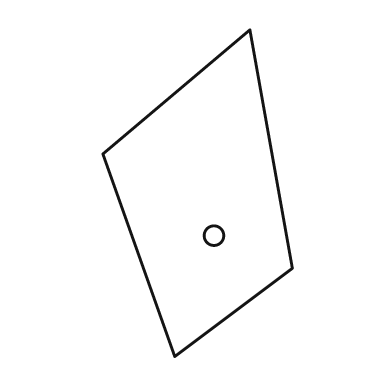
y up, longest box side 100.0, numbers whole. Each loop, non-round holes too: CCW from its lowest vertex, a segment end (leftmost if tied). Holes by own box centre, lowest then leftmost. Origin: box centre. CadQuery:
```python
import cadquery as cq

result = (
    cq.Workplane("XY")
    .moveTo(-7.0, -50.0)
    .lineTo(29.0, -23.0)
    .lineTo(16.0, 50.0)
    .lineTo(-29.0, 12.0)
    .close()
    .moveTo(5.0, -13.0)
    .circle(3.0)
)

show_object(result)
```